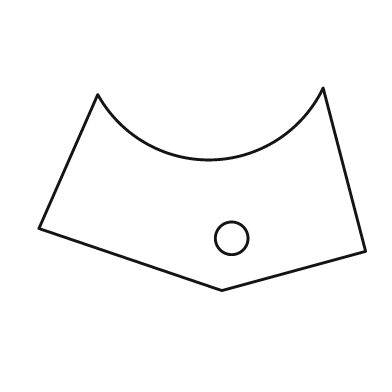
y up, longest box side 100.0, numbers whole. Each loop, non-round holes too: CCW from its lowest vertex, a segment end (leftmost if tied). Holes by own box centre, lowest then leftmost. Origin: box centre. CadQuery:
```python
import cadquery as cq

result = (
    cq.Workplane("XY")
    .moveTo(6.0, -31.0)
    .lineTo(50.0, -19.0)
    .lineTo(37.0, 31.0)
    .threePointArc((3.0, 9.0), (-32.0, 29.0))
    .lineTo(-50.0, -12.0)
    .close()
    .moveTo(9.0, -15.0)
    .circle(5.0)
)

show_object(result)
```